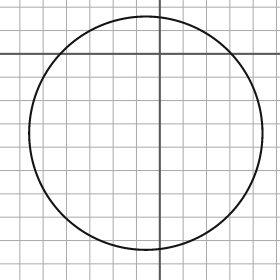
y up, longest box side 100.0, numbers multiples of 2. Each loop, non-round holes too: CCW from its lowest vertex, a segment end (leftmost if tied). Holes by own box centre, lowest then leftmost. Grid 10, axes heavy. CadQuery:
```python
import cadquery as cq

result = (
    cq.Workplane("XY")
    .moveTo(-6.0, -34.0)
    .circle(50.0)
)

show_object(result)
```